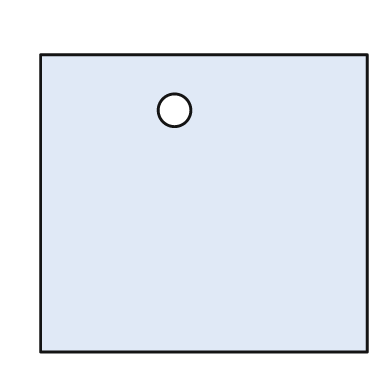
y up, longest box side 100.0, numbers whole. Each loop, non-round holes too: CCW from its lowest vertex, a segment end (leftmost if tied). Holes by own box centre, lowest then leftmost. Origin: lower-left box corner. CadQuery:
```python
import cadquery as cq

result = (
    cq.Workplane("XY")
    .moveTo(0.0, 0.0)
    .lineTo(100.0, 0.0)
    .lineTo(100.0, 91.0)
    .lineTo(0.0, 91.0)
    .close()
    .moveTo(41.0, 74.0)
    .circle(5.0)
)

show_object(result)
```